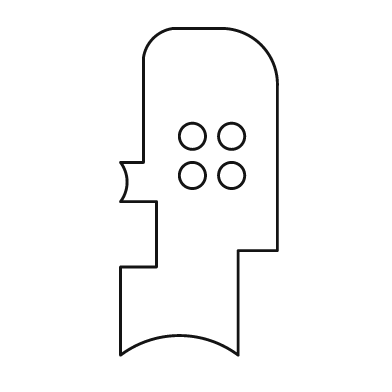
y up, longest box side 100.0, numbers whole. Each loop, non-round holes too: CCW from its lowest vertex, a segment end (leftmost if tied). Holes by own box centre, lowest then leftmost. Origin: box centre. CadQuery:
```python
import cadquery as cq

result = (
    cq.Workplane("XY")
    .moveTo(-24.0, -50.0)
    .threePointArc((-6.0, -44.0), (12.0, -50.0))
    .lineTo(12.0, -18.0)
    .lineTo(24.0, -18.0)
    .lineTo(24.0, 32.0)
    .threePointArc((19.0, 45.0), (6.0, 50.0))
    .lineTo(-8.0, 50.0)
    .threePointArc((-14.0, 47.0), (-17.0, 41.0))
    .lineTo(-17.0, 9.0)
    .lineTo(-24.0, 9.0)
    .threePointArc((-22.0, 3.0), (-24.0, -3.0))
    .lineTo(-13.0, -3.0)
    .lineTo(-13.0, -23.0)
    .lineTo(-24.0, -23.0)
    .close()
    .moveTo(-2.0, 5.0)
    .circle(4.0)
    .moveTo(10.0, 5.0)
    .circle(4.0)
    .moveTo(-2.0, 17.0)
    .circle(4.0)
    .moveTo(10.0, 17.0)
    .circle(4.0)
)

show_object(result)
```